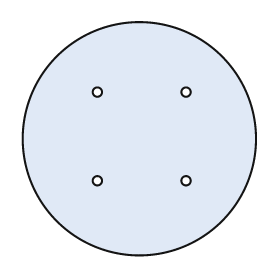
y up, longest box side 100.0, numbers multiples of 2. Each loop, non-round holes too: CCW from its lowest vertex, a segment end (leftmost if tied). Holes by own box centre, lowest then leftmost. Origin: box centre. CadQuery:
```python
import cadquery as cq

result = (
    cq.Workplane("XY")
    .moveTo(0.0, 0.0)
    .circle(50.0)
    .moveTo(-18.0, -18.0)
    .circle(2.0)
    .moveTo(20.0, -18.0)
    .circle(2.0)
    .moveTo(-18.0, 20.0)
    .circle(2.0)
    .moveTo(20.0, 20.0)
    .circle(2.0)
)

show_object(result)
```